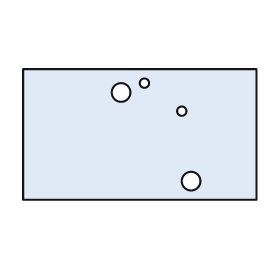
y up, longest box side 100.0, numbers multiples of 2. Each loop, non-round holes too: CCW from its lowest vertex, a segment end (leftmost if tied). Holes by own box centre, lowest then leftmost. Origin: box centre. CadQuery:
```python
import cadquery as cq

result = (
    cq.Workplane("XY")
    .moveTo(-50.0, -28.0)
    .lineTo(50.0, -28.0)
    .lineTo(50.0, 28.0)
    .lineTo(-50.0, 28.0)
    .close()
    .moveTo(22.0, -20.0)
    .circle(4.0)
    .moveTo(18.0, 10.0)
    .circle(2.0)
    .moveTo(-8.0, 18.0)
    .circle(4.0)
    .moveTo(2.0, 22.0)
    .circle(2.0)
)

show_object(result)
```